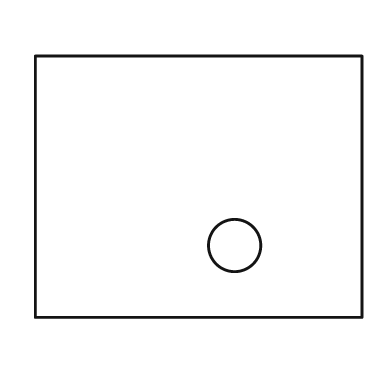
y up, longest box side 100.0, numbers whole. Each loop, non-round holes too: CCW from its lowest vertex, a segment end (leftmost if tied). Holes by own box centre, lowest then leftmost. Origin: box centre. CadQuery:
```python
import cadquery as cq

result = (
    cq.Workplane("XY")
    .moveTo(-50.0, -40.0)
    .lineTo(50.0, -40.0)
    .lineTo(50.0, 40.0)
    .lineTo(-50.0, 40.0)
    .close()
    .moveTo(11.0, -18.0)
    .circle(8.0)
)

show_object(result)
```